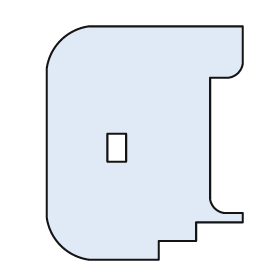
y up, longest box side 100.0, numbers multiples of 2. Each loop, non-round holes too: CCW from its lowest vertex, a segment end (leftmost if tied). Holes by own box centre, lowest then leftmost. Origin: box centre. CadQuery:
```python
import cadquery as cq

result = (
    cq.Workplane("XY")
    .moveTo(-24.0, -50.0)
    .lineTo(6.0, -50.0)
    .lineTo(6.0, -42.0)
    .lineTo(22.0, -42.0)
    .lineTo(22.0, -34.0)
    .lineTo(42.0, -34.0)
    .lineTo(42.0, -30.0)
    .lineTo(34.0, -30.0)
    .threePointArc((30.0, -28.0), (28.0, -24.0))
    .lineTo(28.0, 28.0)
    .lineTo(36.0, 28.0)
    .threePointArc((40.0, 30.0), (42.0, 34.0))
    .lineTo(42.0, 50.0)
    .lineTo(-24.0, 50.0)
    .threePointArc((-36.0, 44.0), (-42.0, 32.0))
    .lineTo(-42.0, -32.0)
    .threePointArc((-36.0, -44.0), (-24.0, -50.0))
    .close()
    .moveTo(-16.0, -8.0)
    .lineTo(-8.0, -8.0)
    .lineTo(-8.0, 4.0)
    .lineTo(-16.0, 4.0)
    .close()
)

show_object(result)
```